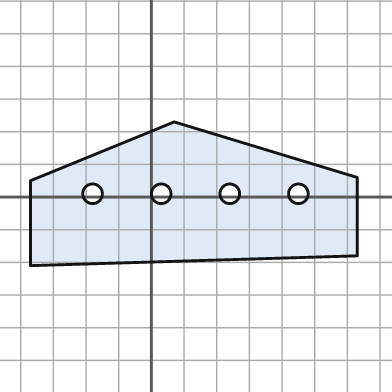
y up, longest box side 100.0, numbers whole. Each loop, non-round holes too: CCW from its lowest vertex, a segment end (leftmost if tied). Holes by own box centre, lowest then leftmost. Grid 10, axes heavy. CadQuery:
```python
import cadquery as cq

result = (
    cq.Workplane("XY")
    .moveTo(-37.0, -21.0)
    .lineTo(63.0, -18.0)
    .lineTo(63.0, 6.0)
    .lineTo(7.0, 23.0)
    .lineTo(-37.0, 5.0)
    .close()
    .moveTo(-18.0, 1.0)
    .circle(3.0)
    .moveTo(3.0, 1.0)
    .circle(3.0)
    .moveTo(24.0, 1.0)
    .circle(3.0)
    .moveTo(45.0, 1.0)
    .circle(3.0)
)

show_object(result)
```